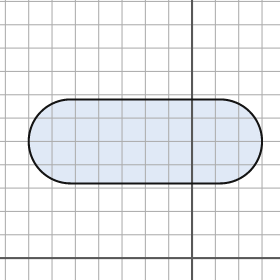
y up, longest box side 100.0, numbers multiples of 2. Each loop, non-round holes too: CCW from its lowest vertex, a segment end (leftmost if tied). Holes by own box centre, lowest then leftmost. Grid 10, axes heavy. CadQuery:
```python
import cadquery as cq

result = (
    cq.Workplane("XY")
    .moveTo(-52.0, 32.0)
    .lineTo(12.0, 32.0)
    .threePointArc((30.0, 50.0), (12.0, 68.0))
    .lineTo(-52.0, 68.0)
    .threePointArc((-70.0, 50.0), (-52.0, 32.0))
    .close()
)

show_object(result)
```